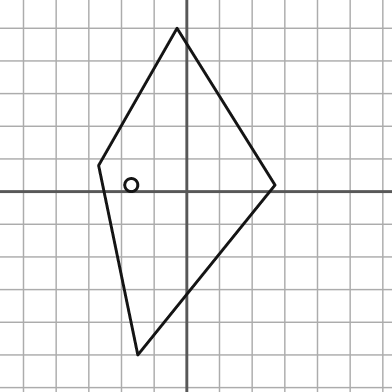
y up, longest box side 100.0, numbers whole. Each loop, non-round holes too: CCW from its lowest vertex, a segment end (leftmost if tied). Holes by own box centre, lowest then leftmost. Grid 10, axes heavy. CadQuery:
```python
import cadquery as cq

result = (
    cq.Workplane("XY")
    .moveTo(-15.0, -50.0)
    .lineTo(27.0, 2.0)
    .lineTo(-3.0, 50.0)
    .lineTo(-27.0, 8.0)
    .close()
    .moveTo(-17.0, 2.0)
    .circle(2.0)
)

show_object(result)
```